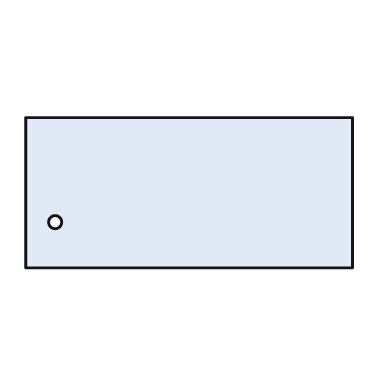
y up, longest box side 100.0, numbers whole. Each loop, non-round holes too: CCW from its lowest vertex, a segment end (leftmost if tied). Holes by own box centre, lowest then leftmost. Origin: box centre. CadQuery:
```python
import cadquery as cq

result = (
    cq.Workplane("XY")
    .moveTo(-50.0, -23.0)
    .lineTo(50.0, -23.0)
    .lineTo(50.0, 23.0)
    .lineTo(-50.0, 23.0)
    .close()
    .moveTo(-41.0, -9.0)
    .circle(2.0)
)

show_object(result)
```